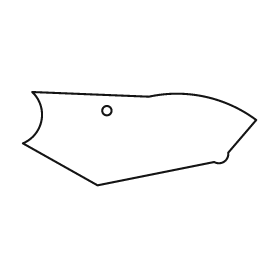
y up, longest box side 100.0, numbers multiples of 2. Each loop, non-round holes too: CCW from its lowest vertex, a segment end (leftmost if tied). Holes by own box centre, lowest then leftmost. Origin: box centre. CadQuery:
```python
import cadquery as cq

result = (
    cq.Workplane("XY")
    .moveTo(-18.0, -20.0)
    .lineTo(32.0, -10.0)
    .threePointArc((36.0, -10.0), (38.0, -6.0))
    .lineTo(50.0, 8.0)
    .threePointArc((28.0, 18.0), (4.0, 18.0))
    .lineTo(-46.0, 20.0)
    .threePointArc((-42.0, 8.0), (-50.0, -2.0))
    .close()
    .moveTo(-14.0, 12.0)
    .circle(2.0)
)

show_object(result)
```